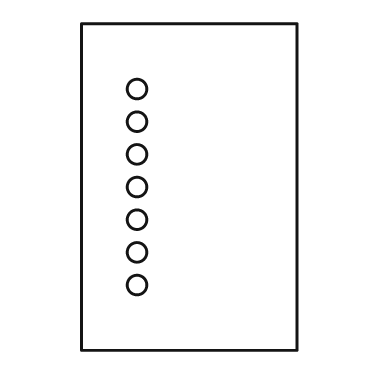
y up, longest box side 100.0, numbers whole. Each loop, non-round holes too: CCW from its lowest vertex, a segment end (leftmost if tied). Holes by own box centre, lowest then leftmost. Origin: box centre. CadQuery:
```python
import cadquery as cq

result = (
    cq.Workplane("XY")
    .moveTo(-33.0, -50.0)
    .lineTo(33.0, -50.0)
    .lineTo(33.0, 50.0)
    .lineTo(-33.0, 50.0)
    .close()
    .moveTo(-16.0, -30.0)
    .circle(3.0)
    .moveTo(-16.0, -20.0)
    .circle(3.0)
    .moveTo(-16.0, -10.0)
    .circle(3.0)
    .moveTo(-16.0, 0.0)
    .circle(3.0)
    .moveTo(-16.0, 10.0)
    .circle(3.0)
    .moveTo(-16.0, 20.0)
    .circle(3.0)
    .moveTo(-16.0, 30.0)
    .circle(3.0)
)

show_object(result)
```